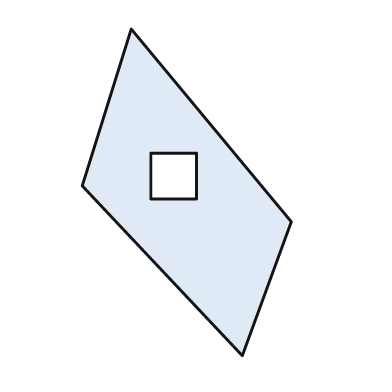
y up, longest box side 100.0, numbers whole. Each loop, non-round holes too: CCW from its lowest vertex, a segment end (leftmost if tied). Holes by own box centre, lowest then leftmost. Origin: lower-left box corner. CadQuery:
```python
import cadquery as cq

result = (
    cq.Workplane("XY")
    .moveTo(49.0, 0.0)
    .lineTo(64.0, 41.0)
    .lineTo(15.0, 100.0)
    .lineTo(0.0, 52.0)
    .close()
    .moveTo(21.0, 48.0)
    .lineTo(35.0, 48.0)
    .lineTo(35.0, 62.0)
    .lineTo(21.0, 62.0)
    .close()
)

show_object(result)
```